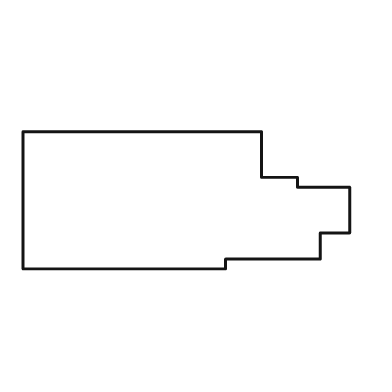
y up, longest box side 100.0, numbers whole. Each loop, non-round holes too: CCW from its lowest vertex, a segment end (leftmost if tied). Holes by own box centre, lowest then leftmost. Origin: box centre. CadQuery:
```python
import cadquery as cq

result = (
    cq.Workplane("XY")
    .moveTo(-50.0, -21.0)
    .lineTo(12.0, -21.0)
    .lineTo(12.0, -18.0)
    .lineTo(41.0, -18.0)
    .lineTo(41.0, -10.0)
    .lineTo(50.0, -10.0)
    .lineTo(50.0, 4.0)
    .lineTo(34.0, 4.0)
    .lineTo(34.0, 7.0)
    .lineTo(23.0, 7.0)
    .lineTo(23.0, 21.0)
    .lineTo(-50.0, 21.0)
    .close()
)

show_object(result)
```